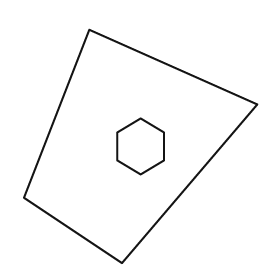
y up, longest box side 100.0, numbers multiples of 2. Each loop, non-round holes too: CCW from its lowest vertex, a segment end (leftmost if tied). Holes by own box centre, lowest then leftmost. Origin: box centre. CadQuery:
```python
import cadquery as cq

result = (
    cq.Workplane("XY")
    .moveTo(-8.0, -50.0)
    .lineTo(50.0, 18.0)
    .lineTo(-22.0, 50.0)
    .lineTo(-50.0, -22.0)
    .close()
    .moveTo(0.0, -12.0)
    .lineTo(10.0, -6.0)
    .lineTo(10.0, 6.0)
    .lineTo(0.0, 12.0)
    .lineTo(-10.0, 6.0)
    .lineTo(-10.0, -6.0)
    .close()
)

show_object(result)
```